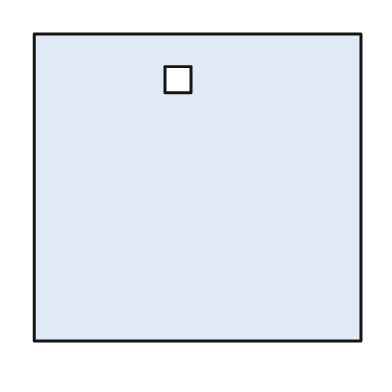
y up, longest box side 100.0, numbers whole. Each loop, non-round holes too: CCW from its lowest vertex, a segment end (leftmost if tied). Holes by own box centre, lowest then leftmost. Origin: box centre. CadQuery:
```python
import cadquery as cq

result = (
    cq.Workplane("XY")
    .moveTo(-50.0, -47.0)
    .lineTo(50.0, -47.0)
    .lineTo(50.0, 47.0)
    .lineTo(-50.0, 47.0)
    .close()
    .moveTo(-10.0, 29.0)
    .lineTo(-2.0, 29.0)
    .lineTo(-2.0, 37.0)
    .lineTo(-10.0, 37.0)
    .close()
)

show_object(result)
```